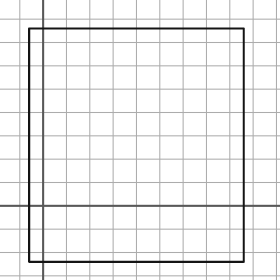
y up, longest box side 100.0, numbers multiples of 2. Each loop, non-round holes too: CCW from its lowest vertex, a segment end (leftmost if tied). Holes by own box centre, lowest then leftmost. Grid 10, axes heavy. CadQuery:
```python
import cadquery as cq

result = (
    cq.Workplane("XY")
    .moveTo(-6.0, -24.0)
    .lineTo(86.0, -24.0)
    .lineTo(86.0, 76.0)
    .lineTo(-6.0, 76.0)
    .close()
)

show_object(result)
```